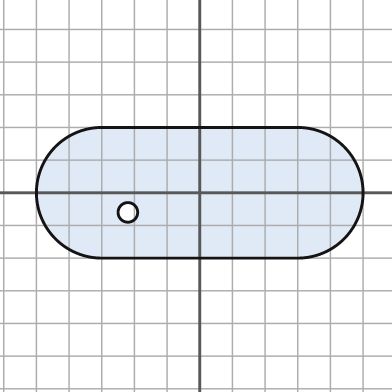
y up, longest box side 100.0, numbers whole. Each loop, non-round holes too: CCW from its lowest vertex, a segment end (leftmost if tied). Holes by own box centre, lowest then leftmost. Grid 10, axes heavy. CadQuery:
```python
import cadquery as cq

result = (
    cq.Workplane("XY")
    .moveTo(-30.0, -20.0)
    .lineTo(30.0, -20.0)
    .threePointArc((50.0, 0.0), (30.0, 20.0))
    .lineTo(-30.0, 20.0)
    .threePointArc((-50.0, 0.0), (-30.0, -20.0))
    .close()
    .moveTo(-22.0, -6.0)
    .circle(3.0)
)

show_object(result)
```